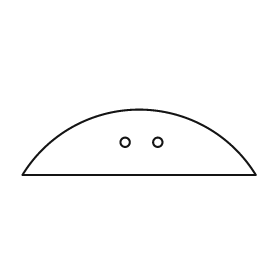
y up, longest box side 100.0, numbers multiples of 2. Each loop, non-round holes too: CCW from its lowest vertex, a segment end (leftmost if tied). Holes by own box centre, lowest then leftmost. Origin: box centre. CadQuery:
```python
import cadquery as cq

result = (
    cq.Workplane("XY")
    .moveTo(-50.0, -14.0)
    .lineTo(50.0, -14.0)
    .threePointArc((0.0, 14.0), (-50.0, -14.0))
    .close()
    .moveTo(-6.0, 0.0)
    .circle(2.0)
    .moveTo(8.0, 0.0)
    .circle(2.0)
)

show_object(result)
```